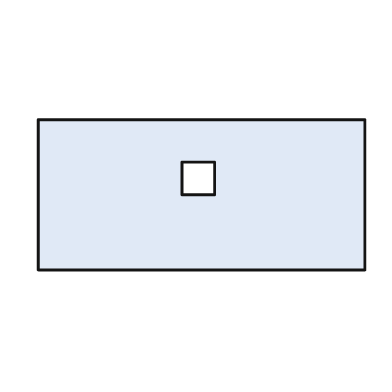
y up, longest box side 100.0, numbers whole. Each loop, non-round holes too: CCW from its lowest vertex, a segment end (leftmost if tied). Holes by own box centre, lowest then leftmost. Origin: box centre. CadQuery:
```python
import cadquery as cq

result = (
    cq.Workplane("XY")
    .moveTo(-50.0, -23.0)
    .lineTo(50.0, -23.0)
    .lineTo(50.0, 23.0)
    .lineTo(-50.0, 23.0)
    .close()
    .moveTo(-6.0, 0.0)
    .lineTo(4.0, 0.0)
    .lineTo(4.0, 10.0)
    .lineTo(-6.0, 10.0)
    .close()
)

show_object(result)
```